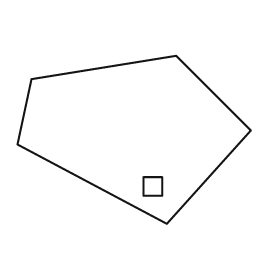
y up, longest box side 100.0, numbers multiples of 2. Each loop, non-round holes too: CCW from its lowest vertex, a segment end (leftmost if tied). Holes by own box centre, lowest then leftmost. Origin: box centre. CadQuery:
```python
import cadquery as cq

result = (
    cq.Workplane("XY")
    .moveTo(14.0, -36.0)
    .lineTo(50.0, 4.0)
    .lineTo(18.0, 36.0)
    .lineTo(-44.0, 26.0)
    .lineTo(-50.0, -2.0)
    .close()
    .moveTo(4.0, -24.0)
    .lineTo(12.0, -24.0)
    .lineTo(12.0, -16.0)
    .lineTo(4.0, -16.0)
    .close()
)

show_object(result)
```